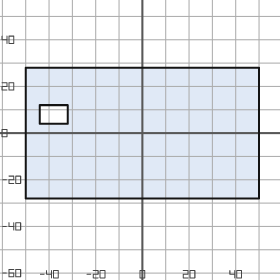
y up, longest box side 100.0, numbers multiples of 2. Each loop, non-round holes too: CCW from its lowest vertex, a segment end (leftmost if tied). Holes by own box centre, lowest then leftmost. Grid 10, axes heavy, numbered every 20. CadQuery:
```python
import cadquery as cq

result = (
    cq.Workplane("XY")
    .moveTo(-50.0, -28.0)
    .lineTo(50.0, -28.0)
    .lineTo(50.0, 28.0)
    .lineTo(-50.0, 28.0)
    .close()
    .moveTo(-44.0, 4.0)
    .lineTo(-32.0, 4.0)
    .lineTo(-32.0, 12.0)
    .lineTo(-44.0, 12.0)
    .close()
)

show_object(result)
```